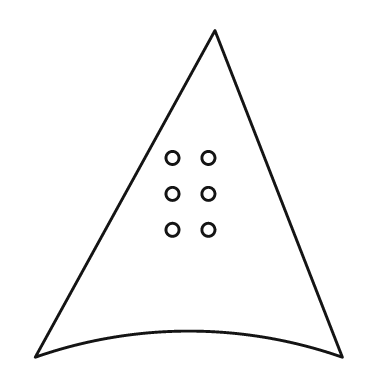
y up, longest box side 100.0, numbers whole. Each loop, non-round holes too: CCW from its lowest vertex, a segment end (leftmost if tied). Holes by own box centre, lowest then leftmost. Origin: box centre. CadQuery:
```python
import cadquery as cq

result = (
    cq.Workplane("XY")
    .moveTo(-47.0, -50.0)
    .threePointArc((0.0, -42.0), (47.0, -50.0))
    .lineTo(8.0, 50.0)
    .close()
    .moveTo(-5.0, -11.0)
    .circle(2.0)
    .moveTo(6.0, -11.0)
    .circle(2.0)
    .moveTo(-5.0, 0.0)
    .circle(2.0)
    .moveTo(6.0, 0.0)
    .circle(2.0)
    .moveTo(-5.0, 11.0)
    .circle(2.0)
    .moveTo(6.0, 11.0)
    .circle(2.0)
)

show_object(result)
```